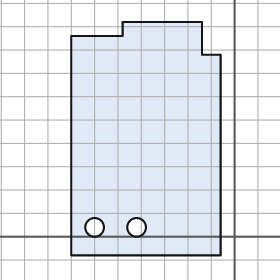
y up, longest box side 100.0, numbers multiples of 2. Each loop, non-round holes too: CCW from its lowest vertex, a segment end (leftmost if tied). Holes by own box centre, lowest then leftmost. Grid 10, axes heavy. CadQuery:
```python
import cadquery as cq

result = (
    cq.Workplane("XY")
    .moveTo(-70.0, -8.0)
    .lineTo(-6.0, -8.0)
    .lineTo(-6.0, 78.0)
    .lineTo(-14.0, 78.0)
    .lineTo(-14.0, 92.0)
    .lineTo(-48.0, 92.0)
    .lineTo(-48.0, 86.0)
    .lineTo(-70.0, 86.0)
    .close()
    .moveTo(-60.0, 4.0)
    .circle(4.0)
    .moveTo(-42.0, 4.0)
    .circle(4.0)
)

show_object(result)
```